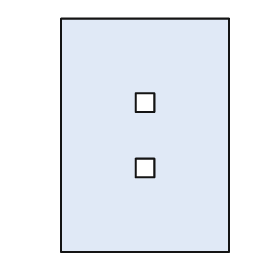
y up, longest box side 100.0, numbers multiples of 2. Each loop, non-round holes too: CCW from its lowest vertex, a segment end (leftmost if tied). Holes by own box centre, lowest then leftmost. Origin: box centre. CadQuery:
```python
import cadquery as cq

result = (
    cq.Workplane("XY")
    .moveTo(-36.0, -50.0)
    .lineTo(36.0, -50.0)
    .lineTo(36.0, 50.0)
    .lineTo(-36.0, 50.0)
    .close()
    .moveTo(-4.0, -18.0)
    .lineTo(4.0, -18.0)
    .lineTo(4.0, -10.0)
    .lineTo(-4.0, -10.0)
    .close()
    .moveTo(-4.0, 10.0)
    .lineTo(4.0, 10.0)
    .lineTo(4.0, 18.0)
    .lineTo(-4.0, 18.0)
    .close()
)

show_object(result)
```